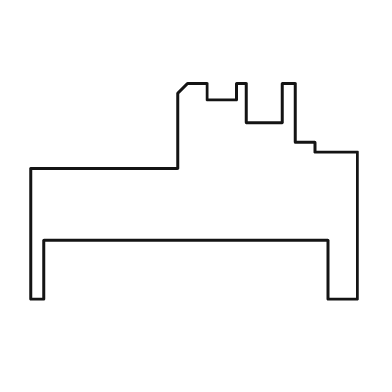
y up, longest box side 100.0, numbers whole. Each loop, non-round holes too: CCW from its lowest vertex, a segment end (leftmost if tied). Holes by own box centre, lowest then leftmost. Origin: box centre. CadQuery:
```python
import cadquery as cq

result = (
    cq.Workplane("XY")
    .moveTo(-50.0, -33.0)
    .lineTo(-46.0, -33.0)
    .lineTo(-46.0, -15.0)
    .lineTo(41.0, -15.0)
    .lineTo(41.0, -33.0)
    .lineTo(50.0, -33.0)
    .lineTo(50.0, 12.0)
    .lineTo(37.0, 12.0)
    .lineTo(37.0, 15.0)
    .lineTo(31.0, 15.0)
    .lineTo(31.0, 33.0)
    .lineTo(27.0, 33.0)
    .lineTo(27.0, 21.0)
    .lineTo(16.0, 21.0)
    .lineTo(16.0, 33.0)
    .lineTo(13.0, 33.0)
    .lineTo(13.0, 28.0)
    .lineTo(4.0, 28.0)
    .lineTo(4.0, 33.0)
    .lineTo(-2.0, 33.0)
    .lineTo(-5.0, 30.0)
    .lineTo(-5.0, 7.0)
    .lineTo(-50.0, 7.0)
    .close()
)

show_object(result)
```